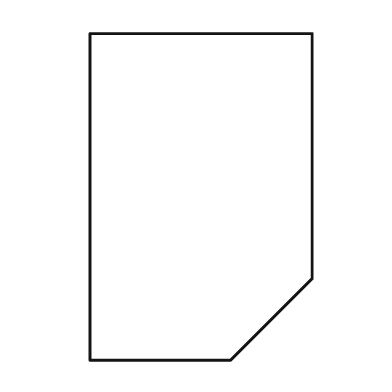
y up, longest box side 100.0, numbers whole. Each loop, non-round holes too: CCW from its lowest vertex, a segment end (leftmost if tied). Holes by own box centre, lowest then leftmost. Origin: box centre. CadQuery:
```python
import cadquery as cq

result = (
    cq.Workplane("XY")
    .moveTo(-34.0, -50.0)
    .lineTo(9.0, -50.0)
    .lineTo(34.0, -25.0)
    .lineTo(34.0, 50.0)
    .lineTo(-34.0, 50.0)
    .close()
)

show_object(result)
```